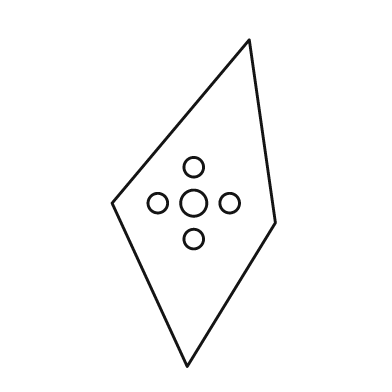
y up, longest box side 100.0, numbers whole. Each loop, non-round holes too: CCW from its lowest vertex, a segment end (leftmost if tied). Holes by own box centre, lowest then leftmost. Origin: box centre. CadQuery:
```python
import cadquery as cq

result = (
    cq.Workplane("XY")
    .moveTo(-2.0, -50.0)
    .lineTo(25.0, -6.0)
    .lineTo(17.0, 50.0)
    .lineTo(-25.0, 0.0)
    .close()
    .moveTo(0.0, -11.0)
    .circle(3.0)
    .moveTo(-11.0, 0.0)
    .circle(3.0)
    .moveTo(0.0, 0.0)
    .circle(4.0)
    .moveTo(11.0, 0.0)
    .circle(3.0)
    .moveTo(0.0, 11.0)
    .circle(3.0)
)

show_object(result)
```